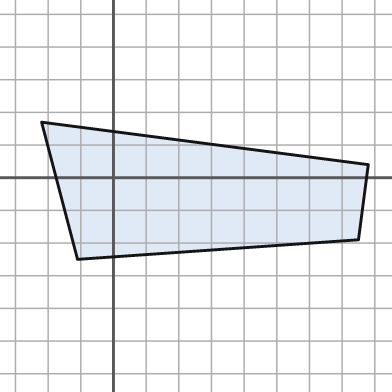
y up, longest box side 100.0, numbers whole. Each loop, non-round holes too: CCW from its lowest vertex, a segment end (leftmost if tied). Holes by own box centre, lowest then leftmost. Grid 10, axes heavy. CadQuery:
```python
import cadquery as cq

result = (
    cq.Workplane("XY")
    .moveTo(-11.0, -25.0)
    .lineTo(75.0, -19.0)
    .lineTo(78.0, 4.0)
    .lineTo(-22.0, 17.0)
    .close()
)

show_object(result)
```